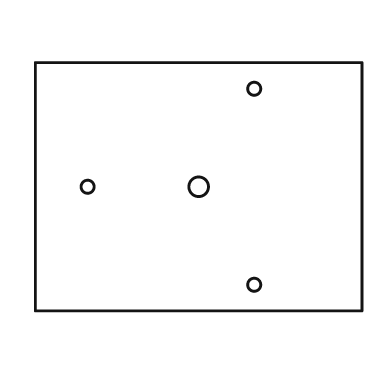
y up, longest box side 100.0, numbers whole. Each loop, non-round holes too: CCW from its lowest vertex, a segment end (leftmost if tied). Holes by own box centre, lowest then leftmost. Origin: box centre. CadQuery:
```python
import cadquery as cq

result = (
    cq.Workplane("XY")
    .moveTo(-50.0, -38.0)
    .lineTo(50.0, -38.0)
    .lineTo(50.0, 38.0)
    .lineTo(-50.0, 38.0)
    .close()
    .moveTo(17.0, -30.0)
    .circle(2.0)
    .moveTo(-34.0, 0.0)
    .circle(2.0)
    .moveTo(0.0, 0.0)
    .circle(3.0)
    .moveTo(17.0, 30.0)
    .circle(2.0)
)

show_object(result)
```